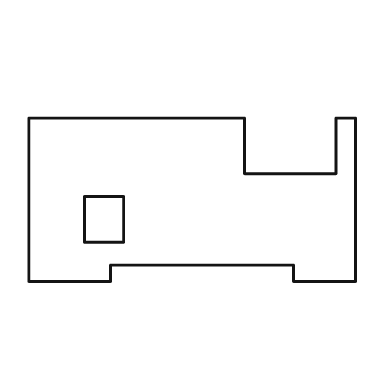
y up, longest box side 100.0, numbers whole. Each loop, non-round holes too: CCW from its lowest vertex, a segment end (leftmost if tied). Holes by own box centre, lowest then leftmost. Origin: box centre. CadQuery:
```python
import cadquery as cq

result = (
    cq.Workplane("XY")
    .moveTo(-50.0, -25.0)
    .lineTo(-25.0, -25.0)
    .lineTo(-25.0, -20.0)
    .lineTo(31.0, -20.0)
    .lineTo(31.0, -25.0)
    .lineTo(50.0, -25.0)
    .lineTo(50.0, 25.0)
    .lineTo(44.0, 25.0)
    .lineTo(44.0, 8.0)
    .lineTo(16.0, 8.0)
    .lineTo(16.0, 25.0)
    .lineTo(-50.0, 25.0)
    .close()
    .moveTo(-33.0, -13.0)
    .lineTo(-21.0, -13.0)
    .lineTo(-21.0, 1.0)
    .lineTo(-33.0, 1.0)
    .close()
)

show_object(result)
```